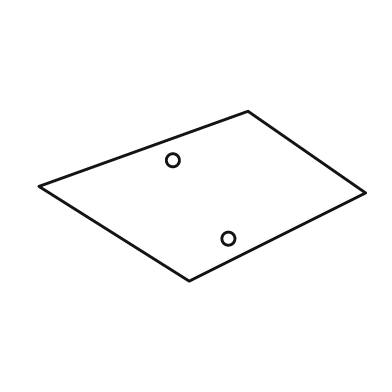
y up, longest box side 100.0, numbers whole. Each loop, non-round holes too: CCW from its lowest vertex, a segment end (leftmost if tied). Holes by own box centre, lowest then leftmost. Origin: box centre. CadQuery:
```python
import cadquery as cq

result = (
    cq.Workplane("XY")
    .moveTo(-4.0, -26.0)
    .lineTo(50.0, 1.0)
    .lineTo(14.0, 26.0)
    .lineTo(-50.0, 3.0)
    .close()
    .moveTo(8.0, -13.0)
    .circle(2.0)
    .moveTo(-9.0, 11.0)
    .circle(2.0)
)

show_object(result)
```